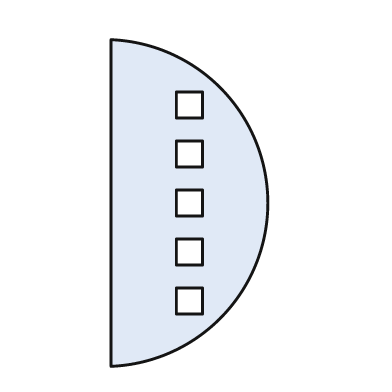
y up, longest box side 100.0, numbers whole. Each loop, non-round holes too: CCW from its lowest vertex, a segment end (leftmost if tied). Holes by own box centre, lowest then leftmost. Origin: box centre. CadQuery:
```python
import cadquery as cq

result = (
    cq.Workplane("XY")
    .moveTo(-24.0, -50.0)
    .threePointArc((24.0, 0.0), (-24.0, 50.0))
    .close()
    .moveTo(-4.0, -34.0)
    .lineTo(4.0, -34.0)
    .lineTo(4.0, -26.0)
    .lineTo(-4.0, -26.0)
    .close()
    .moveTo(-4.0, -19.0)
    .lineTo(4.0, -19.0)
    .lineTo(4.0, -11.0)
    .lineTo(-4.0, -11.0)
    .close()
    .moveTo(-4.0, -4.0)
    .lineTo(4.0, -4.0)
    .lineTo(4.0, 4.0)
    .lineTo(-4.0, 4.0)
    .close()
    .moveTo(-4.0, 11.0)
    .lineTo(4.0, 11.0)
    .lineTo(4.0, 19.0)
    .lineTo(-4.0, 19.0)
    .close()
    .moveTo(-4.0, 26.0)
    .lineTo(4.0, 26.0)
    .lineTo(4.0, 34.0)
    .lineTo(-4.0, 34.0)
    .close()
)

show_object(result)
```